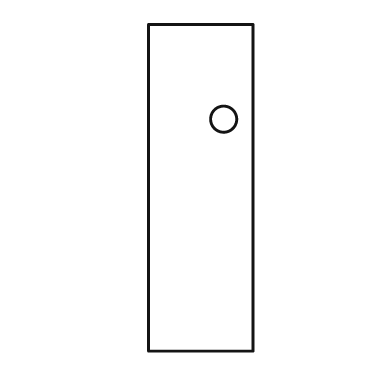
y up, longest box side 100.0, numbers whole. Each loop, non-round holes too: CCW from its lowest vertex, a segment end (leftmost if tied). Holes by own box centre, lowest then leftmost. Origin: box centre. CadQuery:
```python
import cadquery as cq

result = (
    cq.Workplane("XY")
    .moveTo(-16.0, -50.0)
    .lineTo(16.0, -50.0)
    .lineTo(16.0, 50.0)
    .lineTo(-16.0, 50.0)
    .close()
    .moveTo(7.0, 21.0)
    .circle(4.0)
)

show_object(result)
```